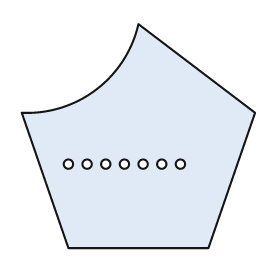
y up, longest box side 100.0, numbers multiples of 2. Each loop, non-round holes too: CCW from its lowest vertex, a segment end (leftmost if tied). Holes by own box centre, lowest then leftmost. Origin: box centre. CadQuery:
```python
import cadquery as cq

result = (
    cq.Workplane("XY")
    .moveTo(-30.0, -48.0)
    .lineTo(30.0, -48.0)
    .lineTo(50.0, 10.0)
    .lineTo(0.0, 48.0)
    .threePointArc((-18.0, 20.0), (-50.0, 10.0))
    .close()
    .moveTo(-30.0, -12.0)
    .circle(2.0)
    .moveTo(-22.0, -12.0)
    .circle(2.0)
    .moveTo(-14.0, -12.0)
    .circle(2.0)
    .moveTo(-6.0, -12.0)
    .circle(2.0)
    .moveTo(2.0, -12.0)
    .circle(2.0)
    .moveTo(10.0, -12.0)
    .circle(2.0)
    .moveTo(18.0, -12.0)
    .circle(2.0)
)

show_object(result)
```